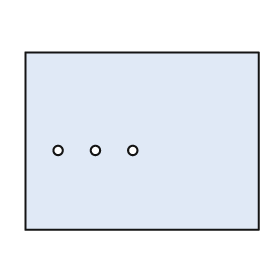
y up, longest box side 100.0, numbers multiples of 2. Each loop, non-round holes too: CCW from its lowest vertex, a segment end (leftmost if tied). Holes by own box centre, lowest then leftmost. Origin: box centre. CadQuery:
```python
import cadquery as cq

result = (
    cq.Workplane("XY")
    .moveTo(-50.0, -38.0)
    .lineTo(50.0, -38.0)
    .lineTo(50.0, 38.0)
    .lineTo(-50.0, 38.0)
    .close()
    .moveTo(-36.0, -4.0)
    .circle(2.0)
    .moveTo(-20.0, -4.0)
    .circle(2.0)
    .moveTo(-4.0, -4.0)
    .circle(2.0)
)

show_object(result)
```